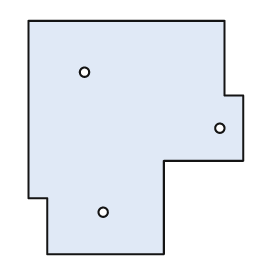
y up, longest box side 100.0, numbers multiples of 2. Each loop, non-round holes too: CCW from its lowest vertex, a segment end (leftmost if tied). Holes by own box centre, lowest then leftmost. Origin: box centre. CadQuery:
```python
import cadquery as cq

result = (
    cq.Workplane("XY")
    .moveTo(-38.0, -50.0)
    .lineTo(12.0, -50.0)
    .lineTo(12.0, -10.0)
    .lineTo(46.0, -10.0)
    .lineTo(46.0, 18.0)
    .lineTo(38.0, 18.0)
    .lineTo(38.0, 50.0)
    .lineTo(-46.0, 50.0)
    .lineTo(-46.0, -26.0)
    .lineTo(-38.0, -26.0)
    .close()
    .moveTo(-14.0, -32.0)
    .circle(2.0)
    .moveTo(36.0, 4.0)
    .circle(2.0)
    .moveTo(-22.0, 28.0)
    .circle(2.0)
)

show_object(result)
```